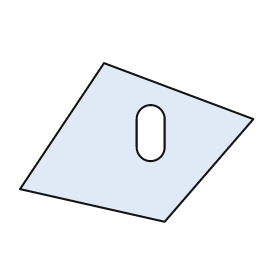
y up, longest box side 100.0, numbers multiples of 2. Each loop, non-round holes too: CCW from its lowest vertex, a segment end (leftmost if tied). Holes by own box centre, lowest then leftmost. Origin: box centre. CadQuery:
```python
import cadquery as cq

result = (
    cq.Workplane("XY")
    .moveTo(12.0, -34.0)
    .lineTo(50.0, 10.0)
    .lineTo(-14.0, 34.0)
    .lineTo(-50.0, -20.0)
    .close()
    .moveTo(0.0, -2.0)
    .threePointArc((6.0, -8.0), (12.0, -2.0))
    .lineTo(12.0, 10.0)
    .threePointArc((6.0, 16.0), (0.0, 10.0))
    .close()
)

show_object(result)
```